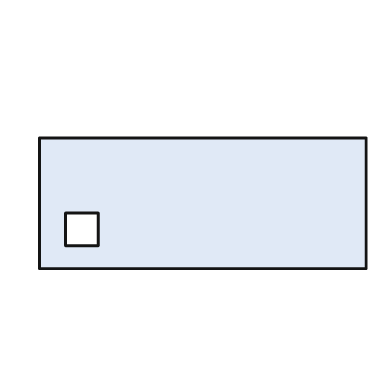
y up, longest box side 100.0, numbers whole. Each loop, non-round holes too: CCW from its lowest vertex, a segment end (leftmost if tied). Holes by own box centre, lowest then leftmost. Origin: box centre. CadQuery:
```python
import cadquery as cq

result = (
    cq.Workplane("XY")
    .moveTo(-50.0, -20.0)
    .lineTo(50.0, -20.0)
    .lineTo(50.0, 20.0)
    .lineTo(-50.0, 20.0)
    .close()
    .moveTo(-42.0, -13.0)
    .lineTo(-32.0, -13.0)
    .lineTo(-32.0, -3.0)
    .lineTo(-42.0, -3.0)
    .close()
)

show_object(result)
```